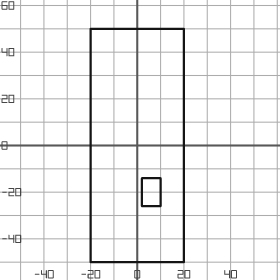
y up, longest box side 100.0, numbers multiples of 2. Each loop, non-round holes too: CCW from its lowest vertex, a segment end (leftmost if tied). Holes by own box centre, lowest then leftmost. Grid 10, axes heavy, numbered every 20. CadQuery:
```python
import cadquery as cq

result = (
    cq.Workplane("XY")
    .moveTo(-20.0, -50.0)
    .lineTo(20.0, -50.0)
    .lineTo(20.0, 50.0)
    .lineTo(-20.0, 50.0)
    .close()
    .moveTo(2.0, -26.0)
    .lineTo(10.0, -26.0)
    .lineTo(10.0, -14.0)
    .lineTo(2.0, -14.0)
    .close()
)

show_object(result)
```